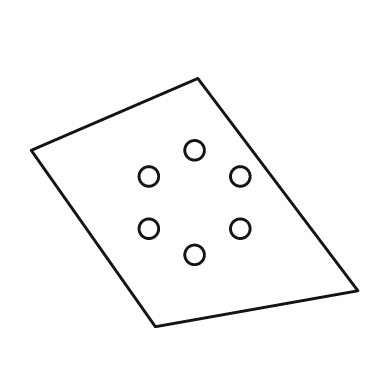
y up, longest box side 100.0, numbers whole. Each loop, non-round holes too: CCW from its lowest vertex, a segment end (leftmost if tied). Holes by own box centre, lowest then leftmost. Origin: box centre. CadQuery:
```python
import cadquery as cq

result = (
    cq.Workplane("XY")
    .moveTo(-12.0, -38.0)
    .lineTo(50.0, -27.0)
    .lineTo(1.0, 38.0)
    .lineTo(-50.0, 16.0)
    .close()
    .moveTo(0.0, -16.0)
    .circle(3.0)
    .moveTo(-14.0, -8.0)
    .circle(3.0)
    .moveTo(14.0, -8.0)
    .circle(3.0)
    .moveTo(-14.0, 8.0)
    .circle(3.0)
    .moveTo(14.0, 8.0)
    .circle(3.0)
    .moveTo(0.0, 16.0)
    .circle(3.0)
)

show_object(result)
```